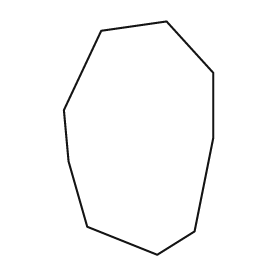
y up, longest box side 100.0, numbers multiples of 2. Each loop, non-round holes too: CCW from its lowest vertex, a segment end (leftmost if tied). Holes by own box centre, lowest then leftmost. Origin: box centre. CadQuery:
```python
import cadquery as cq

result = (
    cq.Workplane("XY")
    .moveTo(8.0, -50.0)
    .lineTo(24.0, -40.0)
    .lineTo(32.0, 0.0)
    .lineTo(32.0, 28.0)
    .lineTo(12.0, 50.0)
    .lineTo(-16.0, 46.0)
    .lineTo(-32.0, 12.0)
    .lineTo(-30.0, -10.0)
    .lineTo(-22.0, -38.0)
    .close()
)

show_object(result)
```